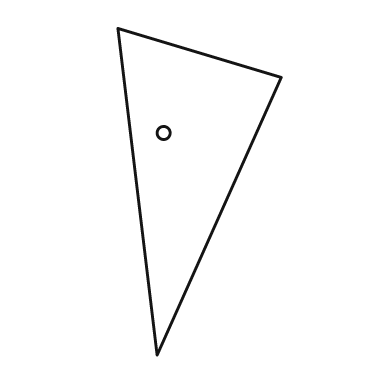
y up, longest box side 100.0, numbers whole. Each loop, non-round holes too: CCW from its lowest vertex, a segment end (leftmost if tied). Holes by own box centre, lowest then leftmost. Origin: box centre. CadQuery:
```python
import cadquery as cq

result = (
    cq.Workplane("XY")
    .moveTo(-13.0, -50.0)
    .lineTo(25.0, 35.0)
    .lineTo(-25.0, 50.0)
    .close()
    .moveTo(-11.0, 18.0)
    .circle(2.0)
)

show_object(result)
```